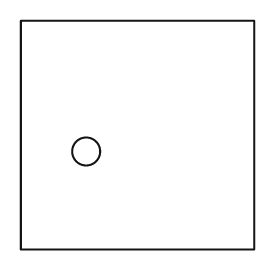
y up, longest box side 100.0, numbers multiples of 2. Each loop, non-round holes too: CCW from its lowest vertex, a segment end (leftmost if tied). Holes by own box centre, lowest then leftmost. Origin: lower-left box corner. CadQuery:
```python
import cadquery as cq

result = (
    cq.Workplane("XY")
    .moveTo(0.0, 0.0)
    .lineTo(100.0, 0.0)
    .lineTo(100.0, 98.0)
    .lineTo(0.0, 98.0)
    .close()
    .moveTo(28.0, 42.0)
    .circle(6.0)
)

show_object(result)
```